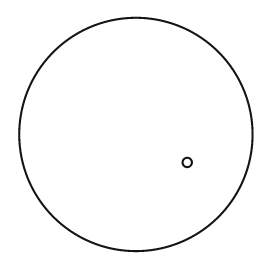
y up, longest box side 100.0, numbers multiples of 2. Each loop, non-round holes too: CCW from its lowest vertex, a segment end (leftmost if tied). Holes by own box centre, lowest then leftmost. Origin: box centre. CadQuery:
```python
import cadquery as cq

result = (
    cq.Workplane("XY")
    .moveTo(0.0, 0.0)
    .circle(50.0)
    .moveTo(22.0, -12.0)
    .circle(2.0)
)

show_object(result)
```